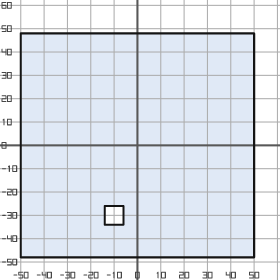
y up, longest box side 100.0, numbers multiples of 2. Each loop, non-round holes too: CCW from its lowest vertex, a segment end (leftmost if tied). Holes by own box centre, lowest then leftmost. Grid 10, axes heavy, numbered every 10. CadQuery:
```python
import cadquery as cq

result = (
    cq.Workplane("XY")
    .moveTo(-50.0, -48.0)
    .lineTo(50.0, -48.0)
    .lineTo(50.0, 48.0)
    .lineTo(-50.0, 48.0)
    .close()
    .moveTo(-14.0, -34.0)
    .lineTo(-6.0, -34.0)
    .lineTo(-6.0, -26.0)
    .lineTo(-14.0, -26.0)
    .close()
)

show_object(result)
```